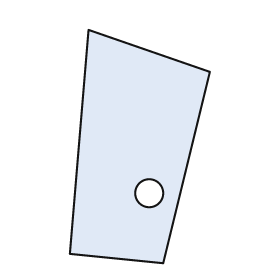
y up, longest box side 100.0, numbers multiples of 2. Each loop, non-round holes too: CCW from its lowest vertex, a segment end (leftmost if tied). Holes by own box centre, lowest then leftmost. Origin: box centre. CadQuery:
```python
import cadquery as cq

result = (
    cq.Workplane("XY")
    .moveTo(10.0, -50.0)
    .lineTo(30.0, 32.0)
    .lineTo(-22.0, 50.0)
    .lineTo(-30.0, -46.0)
    .close()
    .moveTo(4.0, -20.0)
    .circle(6.0)
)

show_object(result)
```